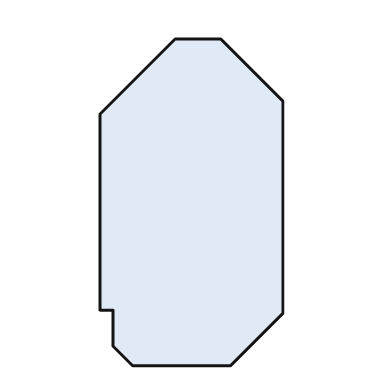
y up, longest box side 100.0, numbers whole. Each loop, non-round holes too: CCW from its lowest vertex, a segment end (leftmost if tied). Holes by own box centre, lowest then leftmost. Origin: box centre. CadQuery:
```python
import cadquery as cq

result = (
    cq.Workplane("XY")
    .moveTo(-18.0, -50.0)
    .lineTo(12.0, -50.0)
    .lineTo(28.0, -34.0)
    .lineTo(28.0, 31.0)
    .lineTo(9.0, 50.0)
    .lineTo(-5.0, 50.0)
    .lineTo(-28.0, 27.0)
    .lineTo(-28.0, -33.0)
    .lineTo(-24.0, -33.0)
    .lineTo(-24.0, -44.0)
    .close()
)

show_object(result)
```